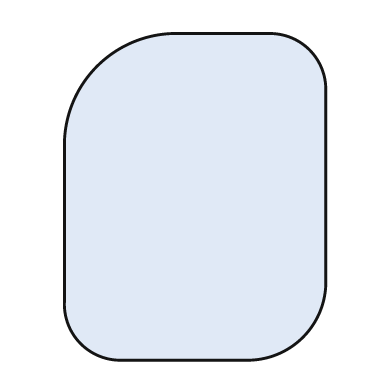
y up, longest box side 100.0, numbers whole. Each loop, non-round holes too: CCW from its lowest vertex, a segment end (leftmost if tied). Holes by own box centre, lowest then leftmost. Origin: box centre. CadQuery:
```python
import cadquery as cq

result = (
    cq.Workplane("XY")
    .moveTo(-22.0, -50.0)
    .lineTo(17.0, -50.0)
    .threePointArc((33.0, -43.0), (40.0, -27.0))
    .lineTo(40.0, 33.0)
    .threePointArc((35.0, 45.0), (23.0, 50.0))
    .lineTo(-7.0, 50.0)
    .threePointArc((-30.0, 40.0), (-40.0, 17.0))
    .lineTo(-40.0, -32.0)
    .threePointArc((-35.0, -45.0), (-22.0, -50.0))
    .close()
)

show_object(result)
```